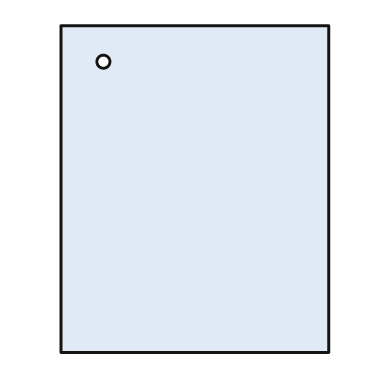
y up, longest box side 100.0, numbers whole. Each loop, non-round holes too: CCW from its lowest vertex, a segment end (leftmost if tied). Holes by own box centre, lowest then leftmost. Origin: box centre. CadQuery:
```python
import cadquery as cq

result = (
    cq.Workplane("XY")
    .moveTo(-41.0, -50.0)
    .lineTo(41.0, -50.0)
    .lineTo(41.0, 50.0)
    .lineTo(-41.0, 50.0)
    .close()
    .moveTo(-28.0, 39.0)
    .circle(2.0)
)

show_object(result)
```